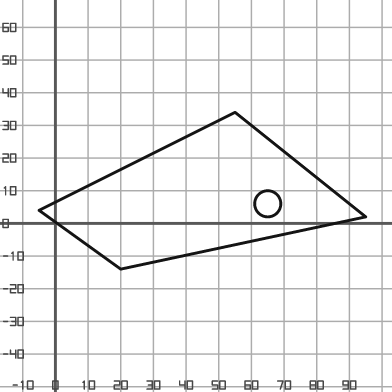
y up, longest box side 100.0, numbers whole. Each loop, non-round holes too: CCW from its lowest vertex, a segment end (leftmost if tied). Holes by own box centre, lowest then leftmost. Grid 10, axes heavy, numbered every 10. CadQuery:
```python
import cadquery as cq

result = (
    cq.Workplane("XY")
    .moveTo(20.0, -14.0)
    .lineTo(95.0, 2.0)
    .lineTo(55.0, 34.0)
    .lineTo(-5.0, 4.0)
    .close()
    .moveTo(65.0, 6.0)
    .circle(4.0)
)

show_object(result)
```